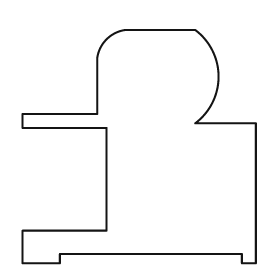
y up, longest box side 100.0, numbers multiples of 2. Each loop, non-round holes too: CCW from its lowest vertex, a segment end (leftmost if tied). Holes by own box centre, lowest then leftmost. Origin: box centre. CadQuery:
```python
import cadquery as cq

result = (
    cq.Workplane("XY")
    .moveTo(-50.0, -50.0)
    .lineTo(-34.0, -50.0)
    .lineTo(-34.0, -46.0)
    .lineTo(44.0, -46.0)
    .lineTo(44.0, -50.0)
    .lineTo(50.0, -50.0)
    .lineTo(50.0, 10.0)
    .lineTo(24.0, 10.0)
    .threePointArc((34.0, 30.0), (24.0, 50.0))
    .lineTo(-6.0, 50.0)
    .threePointArc((-14.0, 46.0), (-18.0, 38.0))
    .lineTo(-18.0, 14.0)
    .lineTo(-50.0, 14.0)
    .lineTo(-50.0, 8.0)
    .lineTo(-14.0, 8.0)
    .lineTo(-14.0, -36.0)
    .lineTo(-50.0, -36.0)
    .close()
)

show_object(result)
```